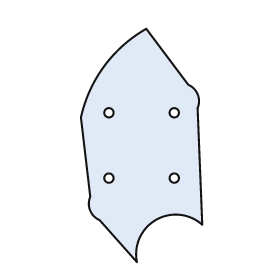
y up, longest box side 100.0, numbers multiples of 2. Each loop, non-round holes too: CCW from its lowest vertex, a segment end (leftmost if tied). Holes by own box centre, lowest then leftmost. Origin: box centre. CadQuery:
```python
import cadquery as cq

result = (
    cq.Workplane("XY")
    .moveTo(-2.0, -50.0)
    .threePointArc((6.0, -32.0), (26.0, -34.0))
    .lineTo(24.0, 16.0)
    .threePointArc((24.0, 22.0), (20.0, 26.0))
    .lineTo(2.0, 50.0)
    .threePointArc((-16.0, 34.0), (-26.0, 12.0))
    .lineTo(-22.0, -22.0)
    .threePointArc((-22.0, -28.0), (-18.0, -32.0))
    .close()
    .moveTo(-14.0, -14.0)
    .circle(2.0)
    .moveTo(14.0, -14.0)
    .circle(2.0)
    .moveTo(-14.0, 14.0)
    .circle(2.0)
    .moveTo(14.0, 14.0)
    .circle(2.0)
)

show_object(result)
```